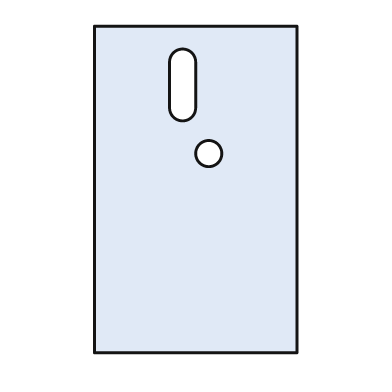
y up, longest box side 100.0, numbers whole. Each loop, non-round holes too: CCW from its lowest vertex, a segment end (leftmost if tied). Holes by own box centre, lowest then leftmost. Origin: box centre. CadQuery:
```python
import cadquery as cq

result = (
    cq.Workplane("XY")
    .moveTo(-31.0, -50.0)
    .lineTo(31.0, -50.0)
    .lineTo(31.0, 50.0)
    .lineTo(-31.0, 50.0)
    .close()
    .moveTo(4.0, 11.0)
    .circle(4.0)
    .moveTo(-8.0, 25.0)
    .threePointArc((-4.0, 21.0), (0.0, 25.0))
    .lineTo(0.0, 39.0)
    .threePointArc((-4.0, 43.0), (-8.0, 39.0))
    .close()
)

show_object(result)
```